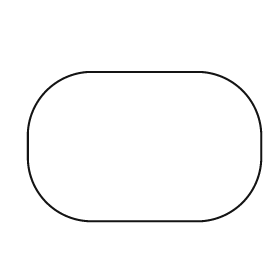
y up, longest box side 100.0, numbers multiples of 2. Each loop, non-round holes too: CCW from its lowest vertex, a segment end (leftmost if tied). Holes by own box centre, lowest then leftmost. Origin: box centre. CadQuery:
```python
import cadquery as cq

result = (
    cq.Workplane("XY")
    .moveTo(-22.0, -32.0)
    .lineTo(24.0, -32.0)
    .threePointArc((42.0, -24.0), (50.0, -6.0))
    .lineTo(50.0, 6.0)
    .threePointArc((42.0, 24.0), (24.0, 32.0))
    .lineTo(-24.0, 32.0)
    .threePointArc((-42.0, 24.0), (-50.0, 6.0))
    .lineTo(-50.0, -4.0)
    .threePointArc((-42.0, -24.0), (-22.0, -32.0))
    .close()
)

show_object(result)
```